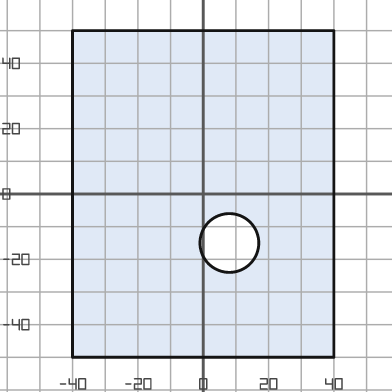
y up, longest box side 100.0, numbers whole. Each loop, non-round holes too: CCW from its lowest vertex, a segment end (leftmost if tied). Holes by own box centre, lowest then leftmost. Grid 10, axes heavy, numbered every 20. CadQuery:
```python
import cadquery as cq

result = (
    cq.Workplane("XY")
    .moveTo(-40.0, -50.0)
    .lineTo(40.0, -50.0)
    .lineTo(40.0, 50.0)
    .lineTo(-40.0, 50.0)
    .close()
    .moveTo(8.0, -15.0)
    .circle(9.0)
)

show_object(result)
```